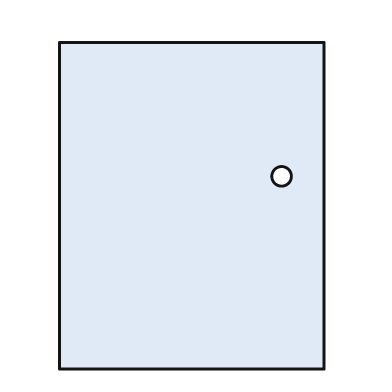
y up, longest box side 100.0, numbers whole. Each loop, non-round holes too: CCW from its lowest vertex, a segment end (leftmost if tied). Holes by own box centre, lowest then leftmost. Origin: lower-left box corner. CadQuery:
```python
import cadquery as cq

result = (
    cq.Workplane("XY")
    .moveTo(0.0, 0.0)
    .lineTo(81.0, 0.0)
    .lineTo(81.0, 100.0)
    .lineTo(0.0, 100.0)
    .close()
    .moveTo(68.0, 59.0)
    .circle(3.0)
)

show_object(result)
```